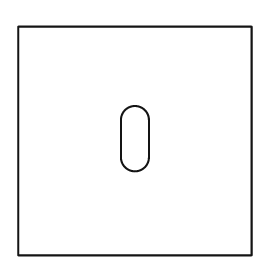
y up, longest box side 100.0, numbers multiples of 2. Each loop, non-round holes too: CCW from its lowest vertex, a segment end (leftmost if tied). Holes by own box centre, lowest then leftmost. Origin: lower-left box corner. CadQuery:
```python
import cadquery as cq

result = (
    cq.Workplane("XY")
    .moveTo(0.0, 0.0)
    .lineTo(100.0, 0.0)
    .lineTo(100.0, 98.0)
    .lineTo(0.0, 98.0)
    .close()
    .moveTo(44.0, 42.0)
    .threePointArc((50.0, 36.0), (56.0, 42.0))
    .lineTo(56.0, 58.0)
    .threePointArc((50.0, 64.0), (44.0, 58.0))
    .close()
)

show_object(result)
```